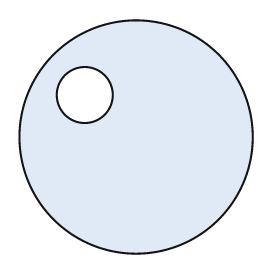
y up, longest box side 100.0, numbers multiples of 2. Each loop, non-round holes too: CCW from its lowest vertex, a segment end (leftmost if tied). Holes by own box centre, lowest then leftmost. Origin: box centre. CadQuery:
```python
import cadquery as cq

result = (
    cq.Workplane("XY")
    .moveTo(0.0, 0.0)
    .circle(50.0)
    .moveTo(-22.0, 18.0)
    .circle(12.0)
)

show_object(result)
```